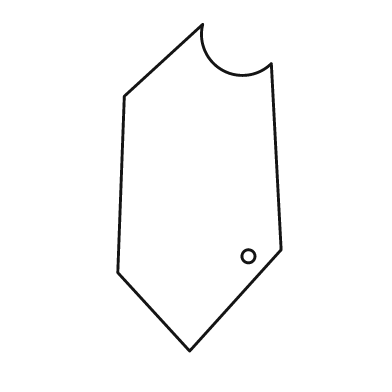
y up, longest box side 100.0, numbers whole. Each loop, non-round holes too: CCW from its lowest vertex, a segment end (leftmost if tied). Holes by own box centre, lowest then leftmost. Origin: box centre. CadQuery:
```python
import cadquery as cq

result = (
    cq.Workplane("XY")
    .moveTo(-3.0, -50.0)
    .lineTo(25.0, -19.0)
    .lineTo(22.0, 38.0)
    .threePointArc((7.0, 36.0), (1.0, 50.0))
    .lineTo(-23.0, 28.0)
    .lineTo(-25.0, -26.0)
    .close()
    .moveTo(15.0, -21.0)
    .circle(2.0)
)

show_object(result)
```